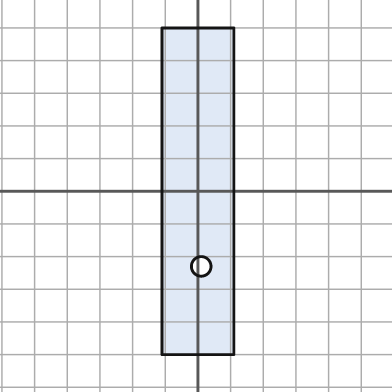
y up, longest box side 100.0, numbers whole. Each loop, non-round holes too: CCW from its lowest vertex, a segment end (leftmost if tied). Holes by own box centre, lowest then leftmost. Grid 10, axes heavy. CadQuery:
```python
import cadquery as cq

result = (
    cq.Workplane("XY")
    .moveTo(-11.0, -50.0)
    .lineTo(11.0, -50.0)
    .lineTo(11.0, 50.0)
    .lineTo(-11.0, 50.0)
    .close()
    .moveTo(1.0, -23.0)
    .circle(3.0)
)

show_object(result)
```